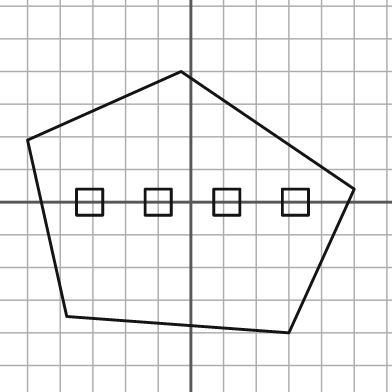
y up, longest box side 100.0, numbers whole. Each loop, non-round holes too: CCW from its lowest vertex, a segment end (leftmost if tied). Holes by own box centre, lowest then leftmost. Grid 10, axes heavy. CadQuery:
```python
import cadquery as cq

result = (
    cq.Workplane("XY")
    .moveTo(30.0, -40.0)
    .lineTo(50.0, 4.0)
    .lineTo(-3.0, 40.0)
    .lineTo(-50.0, 19.0)
    .lineTo(-38.0, -35.0)
    .close()
    .moveTo(-35.0, -4.0)
    .lineTo(-27.0, -4.0)
    .lineTo(-27.0, 4.0)
    .lineTo(-35.0, 4.0)
    .close()
    .moveTo(-14.0, -4.0)
    .lineTo(-6.0, -4.0)
    .lineTo(-6.0, 4.0)
    .lineTo(-14.0, 4.0)
    .close()
    .moveTo(7.0, -4.0)
    .lineTo(15.0, -4.0)
    .lineTo(15.0, 4.0)
    .lineTo(7.0, 4.0)
    .close()
    .moveTo(28.0, -4.0)
    .lineTo(36.0, -4.0)
    .lineTo(36.0, 4.0)
    .lineTo(28.0, 4.0)
    .close()
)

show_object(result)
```